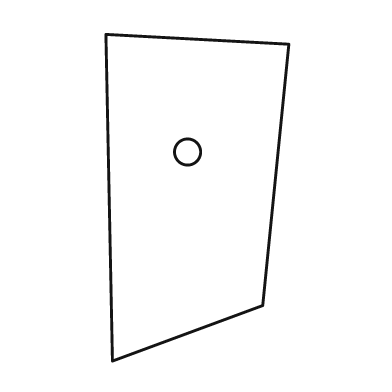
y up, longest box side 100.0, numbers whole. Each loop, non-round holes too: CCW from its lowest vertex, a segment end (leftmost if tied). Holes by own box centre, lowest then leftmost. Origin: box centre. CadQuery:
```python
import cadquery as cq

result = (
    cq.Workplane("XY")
    .moveTo(-26.0, -50.0)
    .lineTo(20.0, -33.0)
    .lineTo(28.0, 47.0)
    .lineTo(-28.0, 50.0)
    .close()
    .moveTo(-3.0, 14.0)
    .circle(4.0)
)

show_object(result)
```